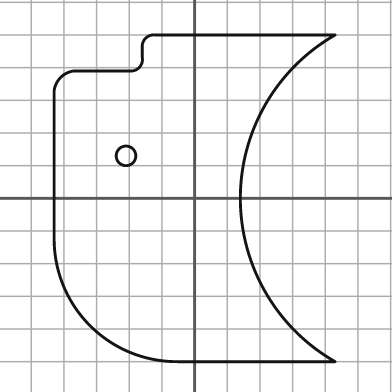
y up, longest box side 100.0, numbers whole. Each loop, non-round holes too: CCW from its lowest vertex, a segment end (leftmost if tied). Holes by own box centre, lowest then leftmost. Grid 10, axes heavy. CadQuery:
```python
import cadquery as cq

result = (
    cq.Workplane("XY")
    .moveTo(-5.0, -50.0)
    .lineTo(43.0, -50.0)
    .threePointArc((14.0, 0.0), (43.0, 50.0))
    .lineTo(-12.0, 50.0)
    .threePointArc((-15.0, 49.0), (-16.0, 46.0))
    .lineTo(-16.0, 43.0)
    .threePointArc((-17.0, 40.0), (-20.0, 39.0))
    .lineTo(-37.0, 39.0)
    .threePointArc((-41.0, 37.0), (-43.0, 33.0))
    .lineTo(-43.0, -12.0)
    .threePointArc((-32.0, -39.0), (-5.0, -50.0))
    .close()
    .moveTo(-21.0, 13.0)
    .circle(3.0)
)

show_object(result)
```